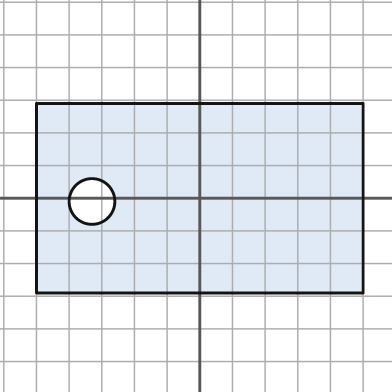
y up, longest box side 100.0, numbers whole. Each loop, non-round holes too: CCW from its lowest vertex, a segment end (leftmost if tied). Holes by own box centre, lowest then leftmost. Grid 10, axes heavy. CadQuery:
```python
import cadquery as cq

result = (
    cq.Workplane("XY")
    .moveTo(-50.0, -29.0)
    .lineTo(50.0, -29.0)
    .lineTo(50.0, 29.0)
    .lineTo(-50.0, 29.0)
    .close()
    .moveTo(-33.0, -1.0)
    .circle(7.0)
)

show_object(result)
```